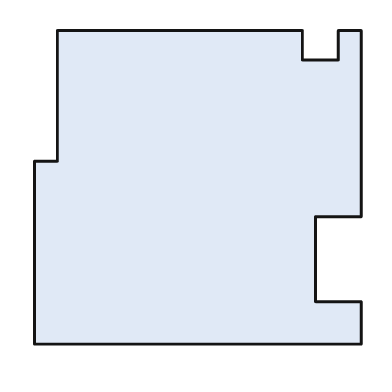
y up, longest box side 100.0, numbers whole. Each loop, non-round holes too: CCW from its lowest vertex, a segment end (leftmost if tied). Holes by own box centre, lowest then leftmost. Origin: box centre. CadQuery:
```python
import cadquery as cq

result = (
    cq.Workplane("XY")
    .moveTo(-50.0, -48.0)
    .lineTo(50.0, -48.0)
    .lineTo(50.0, -35.0)
    .lineTo(36.0, -35.0)
    .lineTo(36.0, -9.0)
    .lineTo(50.0, -9.0)
    .lineTo(50.0, 48.0)
    .lineTo(43.0, 48.0)
    .lineTo(43.0, 39.0)
    .lineTo(32.0, 39.0)
    .lineTo(32.0, 48.0)
    .lineTo(-43.0, 48.0)
    .lineTo(-43.0, 8.0)
    .lineTo(-50.0, 8.0)
    .close()
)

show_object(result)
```